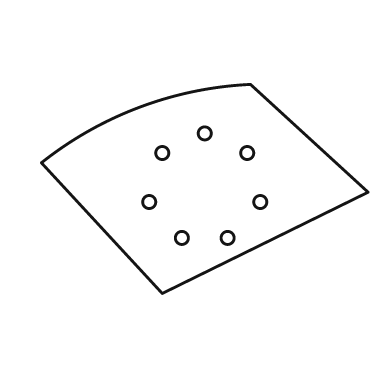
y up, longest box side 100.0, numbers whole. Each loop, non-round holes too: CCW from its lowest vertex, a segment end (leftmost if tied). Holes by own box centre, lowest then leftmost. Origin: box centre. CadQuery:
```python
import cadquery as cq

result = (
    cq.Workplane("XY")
    .moveTo(-13.0, -32.0)
    .lineTo(50.0, -1.0)
    .lineTo(14.0, 32.0)
    .threePointArc((-20.0, 25.0), (-50.0, 8.0))
    .close()
    .moveTo(-7.0, -15.0)
    .circle(2.0)
    .moveTo(7.0, -15.0)
    .circle(2.0)
    .moveTo(-17.0, -4.0)
    .circle(2.0)
    .moveTo(17.0, -4.0)
    .circle(2.0)
    .moveTo(-13.0, 11.0)
    .circle(2.0)
    .moveTo(13.0, 11.0)
    .circle(2.0)
    .moveTo(0.0, 17.0)
    .circle(2.0)
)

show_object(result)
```